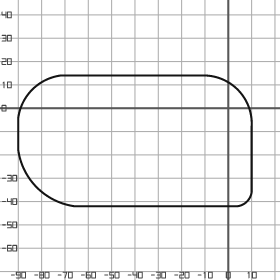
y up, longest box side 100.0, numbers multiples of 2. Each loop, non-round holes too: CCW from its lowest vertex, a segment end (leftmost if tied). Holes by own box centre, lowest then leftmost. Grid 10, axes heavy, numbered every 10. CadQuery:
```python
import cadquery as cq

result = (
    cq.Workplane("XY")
    .moveTo(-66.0, -42.0)
    .lineTo(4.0, -42.0)
    .threePointArc((8.0, -40.0), (10.0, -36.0))
    .lineTo(10.0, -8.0)
    .threePointArc((4.0, 8.0), (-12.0, 14.0))
    .lineTo(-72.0, 14.0)
    .threePointArc((-84.0, 8.0), (-90.0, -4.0))
    .lineTo(-90.0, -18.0)
    .threePointArc((-82.0, -34.0), (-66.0, -42.0))
    .close()
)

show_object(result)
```